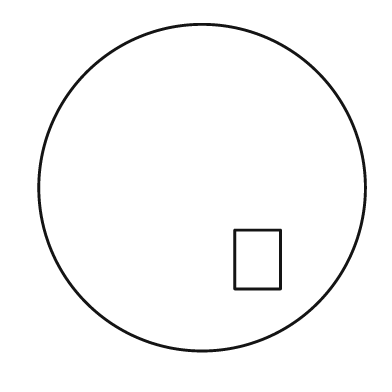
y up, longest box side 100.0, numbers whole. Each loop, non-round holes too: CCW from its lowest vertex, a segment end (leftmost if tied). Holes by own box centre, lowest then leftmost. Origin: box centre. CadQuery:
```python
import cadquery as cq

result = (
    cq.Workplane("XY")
    .moveTo(0.0, 0.0)
    .circle(50.0)
    .moveTo(10.0, -31.0)
    .lineTo(24.0, -31.0)
    .lineTo(24.0, -13.0)
    .lineTo(10.0, -13.0)
    .close()
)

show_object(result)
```